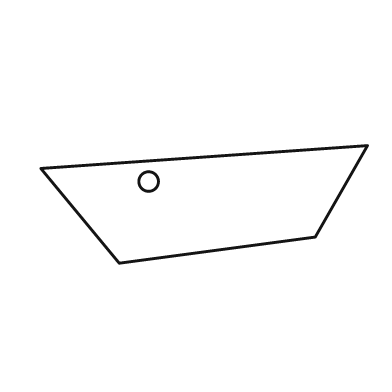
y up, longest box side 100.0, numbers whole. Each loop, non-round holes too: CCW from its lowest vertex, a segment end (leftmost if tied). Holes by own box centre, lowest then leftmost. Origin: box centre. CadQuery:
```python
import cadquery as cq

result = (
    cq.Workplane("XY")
    .moveTo(-26.0, -18.0)
    .lineTo(34.0, -10.0)
    .lineTo(50.0, 18.0)
    .lineTo(-50.0, 11.0)
    .close()
    .moveTo(-17.0, 7.0)
    .circle(3.0)
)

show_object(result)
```